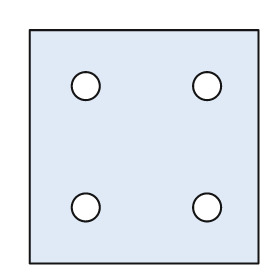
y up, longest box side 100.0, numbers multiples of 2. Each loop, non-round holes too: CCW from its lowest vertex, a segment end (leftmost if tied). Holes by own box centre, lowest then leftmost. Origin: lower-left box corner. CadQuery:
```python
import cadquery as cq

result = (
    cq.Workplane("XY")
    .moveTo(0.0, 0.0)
    .lineTo(98.0, 0.0)
    .lineTo(98.0, 100.0)
    .lineTo(0.0, 100.0)
    .close()
    .moveTo(24.0, 24.0)
    .circle(6.0)
    .moveTo(76.0, 24.0)
    .circle(6.0)
    .moveTo(24.0, 76.0)
    .circle(6.0)
    .moveTo(76.0, 76.0)
    .circle(6.0)
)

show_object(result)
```